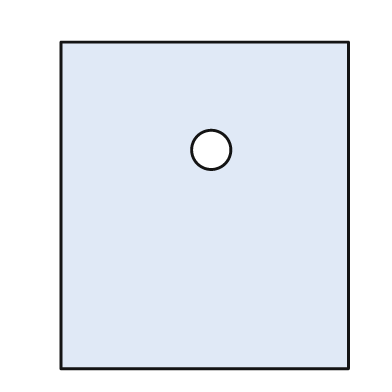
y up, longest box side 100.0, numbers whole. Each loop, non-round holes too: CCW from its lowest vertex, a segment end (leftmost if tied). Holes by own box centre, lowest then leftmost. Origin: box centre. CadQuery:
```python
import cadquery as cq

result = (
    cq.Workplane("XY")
    .moveTo(-44.0, -50.0)
    .lineTo(44.0, -50.0)
    .lineTo(44.0, 50.0)
    .lineTo(-44.0, 50.0)
    .close()
    .moveTo(2.0, 17.0)
    .circle(6.0)
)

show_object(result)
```